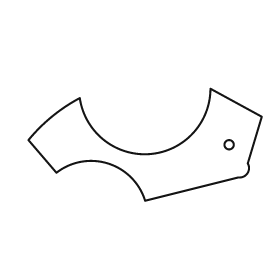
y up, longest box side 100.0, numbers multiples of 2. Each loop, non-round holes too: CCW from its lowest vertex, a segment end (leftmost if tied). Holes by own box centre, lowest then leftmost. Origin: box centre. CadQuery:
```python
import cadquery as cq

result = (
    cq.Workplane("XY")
    .moveTo(0.0, -24.0)
    .lineTo(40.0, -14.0)
    .threePointArc((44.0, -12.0), (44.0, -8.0))
    .lineTo(50.0, 12.0)
    .lineTo(28.0, 24.0)
    .threePointArc((2.0, -4.0), (-28.0, 20.0))
    .threePointArc((-40.0, 12.0), (-50.0, 2.0))
    .lineTo(-38.0, -12.0)
    .threePointArc((-16.0, -8.0), (0.0, -24.0))
    .close()
    .moveTo(36.0, 0.0)
    .circle(2.0)
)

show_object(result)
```